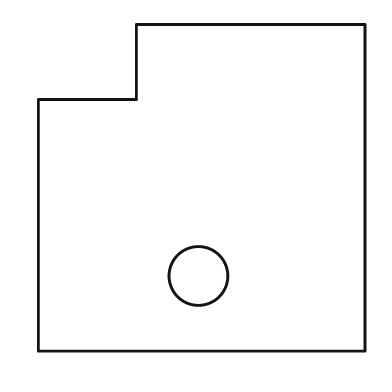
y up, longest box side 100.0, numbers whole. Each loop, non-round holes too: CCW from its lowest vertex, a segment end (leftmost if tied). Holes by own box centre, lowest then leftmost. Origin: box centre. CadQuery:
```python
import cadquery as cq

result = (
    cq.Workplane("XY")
    .moveTo(-50.0, -50.0)
    .lineTo(50.0, -50.0)
    .lineTo(50.0, 50.0)
    .lineTo(-20.0, 50.0)
    .lineTo(-20.0, 27.0)
    .lineTo(-50.0, 27.0)
    .close()
    .moveTo(-1.0, -27.0)
    .circle(9.0)
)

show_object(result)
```